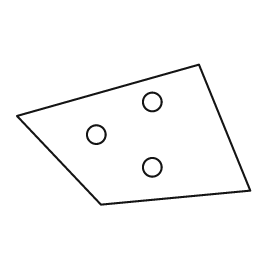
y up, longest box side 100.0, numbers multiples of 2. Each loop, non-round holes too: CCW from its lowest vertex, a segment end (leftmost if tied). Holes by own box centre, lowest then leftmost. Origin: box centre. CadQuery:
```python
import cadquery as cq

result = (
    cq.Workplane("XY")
    .moveTo(-14.0, -30.0)
    .lineTo(50.0, -24.0)
    .lineTo(28.0, 30.0)
    .lineTo(-50.0, 8.0)
    .close()
    .moveTo(8.0, -14.0)
    .circle(4.0)
    .moveTo(-16.0, 0.0)
    .circle(4.0)
    .moveTo(8.0, 14.0)
    .circle(4.0)
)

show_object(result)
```